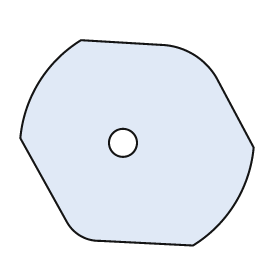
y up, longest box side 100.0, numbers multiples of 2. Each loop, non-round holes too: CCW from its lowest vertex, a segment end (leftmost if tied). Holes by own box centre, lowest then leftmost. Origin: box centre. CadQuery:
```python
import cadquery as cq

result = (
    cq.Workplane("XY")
    .moveTo(24.0, -44.0)
    .threePointArc((42.0, -26.0), (50.0, -2.0))
    .lineTo(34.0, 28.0)
    .threePointArc((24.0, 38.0), (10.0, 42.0))
    .lineTo(-24.0, 44.0)
    .threePointArc((-42.0, 26.0), (-50.0, 2.0))
    .lineTo(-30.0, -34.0)
    .threePointArc((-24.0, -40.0), (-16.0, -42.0))
    .close()
    .moveTo(-6.0, 0.0)
    .circle(6.0)
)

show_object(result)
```